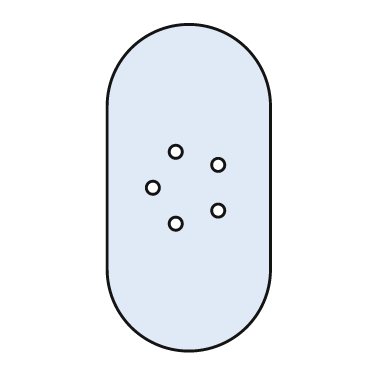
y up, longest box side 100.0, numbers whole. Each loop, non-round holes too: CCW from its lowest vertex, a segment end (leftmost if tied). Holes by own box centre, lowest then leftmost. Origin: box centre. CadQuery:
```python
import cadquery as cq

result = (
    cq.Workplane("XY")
    .moveTo(-25.0, -25.0)
    .threePointArc((0.0, -50.0), (25.0, -25.0))
    .lineTo(25.0, 25.0)
    .threePointArc((0.0, 50.0), (-25.0, 25.0))
    .close()
    .moveTo(-4.0, -11.0)
    .circle(2.0)
    .moveTo(9.0, -7.0)
    .circle(2.0)
    .moveTo(-11.0, 0.0)
    .circle(2.0)
    .moveTo(9.0, 7.0)
    .circle(2.0)
    .moveTo(-4.0, 11.0)
    .circle(2.0)
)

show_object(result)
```